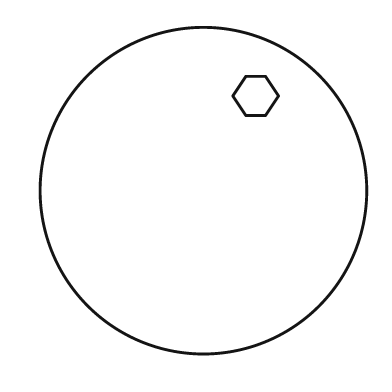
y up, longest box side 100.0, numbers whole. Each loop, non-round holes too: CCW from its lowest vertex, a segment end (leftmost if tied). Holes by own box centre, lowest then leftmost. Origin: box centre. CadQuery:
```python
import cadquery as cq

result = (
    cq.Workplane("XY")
    .moveTo(0.0, 0.0)
    .circle(50.0)
    .moveTo(13.0, 23.0)
    .lineTo(19.0, 23.0)
    .lineTo(23.0, 29.0)
    .lineTo(19.0, 35.0)
    .lineTo(13.0, 35.0)
    .lineTo(9.0, 29.0)
    .close()
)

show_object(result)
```